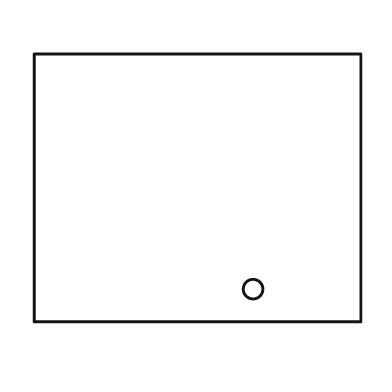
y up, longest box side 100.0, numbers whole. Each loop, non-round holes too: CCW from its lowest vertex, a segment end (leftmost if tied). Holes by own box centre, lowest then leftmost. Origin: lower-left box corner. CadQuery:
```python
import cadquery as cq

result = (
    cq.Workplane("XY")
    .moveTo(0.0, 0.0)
    .lineTo(100.0, 0.0)
    .lineTo(100.0, 82.0)
    .lineTo(0.0, 82.0)
    .close()
    .moveTo(67.0, 10.0)
    .circle(3.0)
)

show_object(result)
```